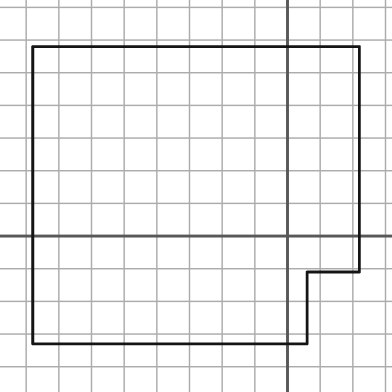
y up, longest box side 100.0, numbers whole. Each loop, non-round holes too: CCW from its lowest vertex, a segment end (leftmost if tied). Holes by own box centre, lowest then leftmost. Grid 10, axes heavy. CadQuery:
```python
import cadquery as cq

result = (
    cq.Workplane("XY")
    .moveTo(-78.0, -33.0)
    .lineTo(6.0, -33.0)
    .lineTo(6.0, -11.0)
    .lineTo(22.0, -11.0)
    .lineTo(22.0, 58.0)
    .lineTo(-78.0, 58.0)
    .close()
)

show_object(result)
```